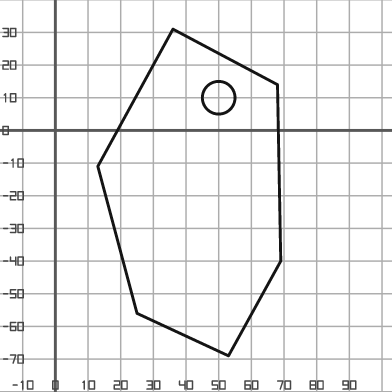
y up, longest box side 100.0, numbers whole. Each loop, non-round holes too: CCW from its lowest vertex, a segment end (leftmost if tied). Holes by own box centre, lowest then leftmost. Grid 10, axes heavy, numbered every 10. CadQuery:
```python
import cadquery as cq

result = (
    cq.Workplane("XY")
    .moveTo(53.0, -69.0)
    .lineTo(69.0, -40.0)
    .lineTo(68.0, 14.0)
    .lineTo(36.0, 31.0)
    .lineTo(13.0, -11.0)
    .lineTo(25.0, -56.0)
    .close()
    .moveTo(50.0, 10.0)
    .circle(5.0)
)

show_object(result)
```